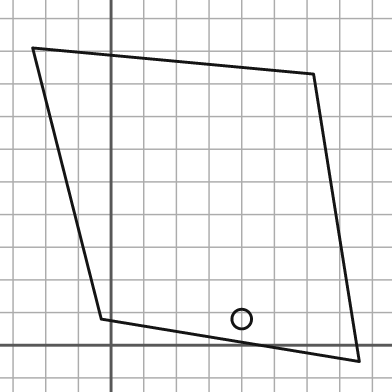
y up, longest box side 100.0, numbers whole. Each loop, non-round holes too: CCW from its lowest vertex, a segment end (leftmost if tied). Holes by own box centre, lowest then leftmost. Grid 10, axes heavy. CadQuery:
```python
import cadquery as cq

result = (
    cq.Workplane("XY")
    .moveTo(76.0, -5.0)
    .lineTo(62.0, 83.0)
    .lineTo(-24.0, 91.0)
    .lineTo(-3.0, 8.0)
    .close()
    .moveTo(40.0, 8.0)
    .circle(3.0)
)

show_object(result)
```